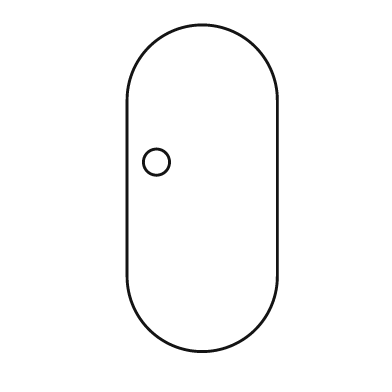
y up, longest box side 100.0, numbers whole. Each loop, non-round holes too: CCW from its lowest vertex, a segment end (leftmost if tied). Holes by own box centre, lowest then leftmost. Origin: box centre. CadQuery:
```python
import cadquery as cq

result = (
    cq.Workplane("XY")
    .moveTo(-23.0, -27.0)
    .threePointArc((0.0, -50.0), (23.0, -27.0))
    .lineTo(23.0, 27.0)
    .threePointArc((0.0, 50.0), (-23.0, 27.0))
    .close()
    .moveTo(-14.0, 8.0)
    .circle(4.0)
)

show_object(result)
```